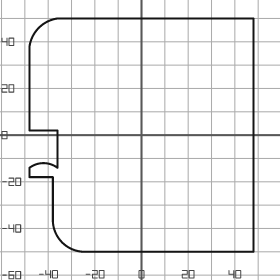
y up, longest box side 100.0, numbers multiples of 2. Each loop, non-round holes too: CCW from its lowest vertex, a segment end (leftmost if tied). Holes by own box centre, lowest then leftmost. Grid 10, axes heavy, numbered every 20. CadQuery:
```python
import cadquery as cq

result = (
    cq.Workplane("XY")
    .moveTo(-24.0, -50.0)
    .lineTo(48.0, -50.0)
    .lineTo(48.0, 50.0)
    .lineTo(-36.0, 50.0)
    .threePointArc((-44.0, 46.0), (-48.0, 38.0))
    .lineTo(-48.0, 2.0)
    .lineTo(-36.0, 2.0)
    .lineTo(-36.0, -14.0)
    .threePointArc((-42.0, -12.0), (-48.0, -14.0))
    .lineTo(-48.0, -18.0)
    .lineTo(-38.0, -18.0)
    .lineTo(-38.0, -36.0)
    .threePointArc((-34.0, -46.0), (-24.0, -50.0))
    .close()
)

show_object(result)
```